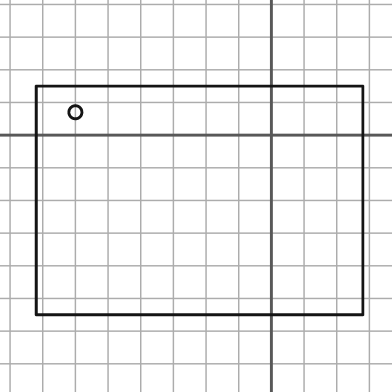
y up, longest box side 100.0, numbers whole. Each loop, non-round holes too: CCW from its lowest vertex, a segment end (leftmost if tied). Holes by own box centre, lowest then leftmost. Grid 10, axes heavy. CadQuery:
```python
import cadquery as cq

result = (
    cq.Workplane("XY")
    .moveTo(-72.0, -55.0)
    .lineTo(28.0, -55.0)
    .lineTo(28.0, 15.0)
    .lineTo(-72.0, 15.0)
    .close()
    .moveTo(-60.0, 7.0)
    .circle(2.0)
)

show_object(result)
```